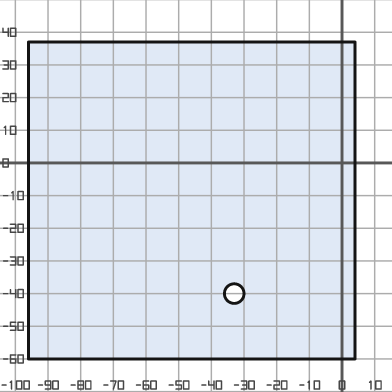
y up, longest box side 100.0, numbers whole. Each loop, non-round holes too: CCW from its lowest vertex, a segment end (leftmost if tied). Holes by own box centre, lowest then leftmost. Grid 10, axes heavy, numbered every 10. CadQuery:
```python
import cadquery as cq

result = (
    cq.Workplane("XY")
    .moveTo(-96.0, -60.0)
    .lineTo(4.0, -60.0)
    .lineTo(4.0, 37.0)
    .lineTo(-96.0, 37.0)
    .close()
    .moveTo(-33.0, -40.0)
    .circle(3.0)
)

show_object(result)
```